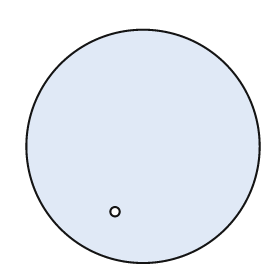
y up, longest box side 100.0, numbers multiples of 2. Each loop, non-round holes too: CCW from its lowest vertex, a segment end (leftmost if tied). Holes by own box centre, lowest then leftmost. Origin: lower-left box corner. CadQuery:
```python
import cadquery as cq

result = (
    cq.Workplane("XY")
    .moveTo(50.0, 50.0)
    .circle(50.0)
    .moveTo(38.0, 22.0)
    .circle(2.0)
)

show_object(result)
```